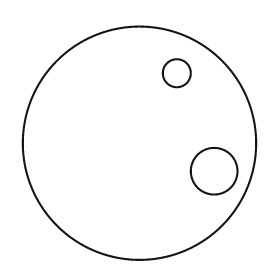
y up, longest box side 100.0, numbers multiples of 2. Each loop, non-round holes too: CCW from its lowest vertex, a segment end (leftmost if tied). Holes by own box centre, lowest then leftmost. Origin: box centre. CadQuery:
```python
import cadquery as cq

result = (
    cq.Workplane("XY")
    .moveTo(0.0, 0.0)
    .circle(50.0)
    .moveTo(32.0, -12.0)
    .circle(10.0)
    .moveTo(16.0, 30.0)
    .circle(6.0)
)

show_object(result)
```